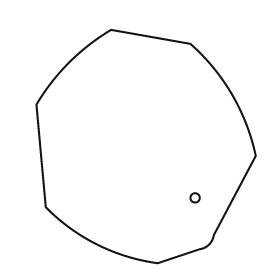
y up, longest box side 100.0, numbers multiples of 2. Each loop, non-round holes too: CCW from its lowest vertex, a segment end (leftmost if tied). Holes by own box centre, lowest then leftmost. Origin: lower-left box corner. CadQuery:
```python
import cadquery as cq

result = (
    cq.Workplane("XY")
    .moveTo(52.0, 0.0)
    .lineTo(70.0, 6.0)
    .threePointArc((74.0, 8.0), (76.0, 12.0))
    .lineTo(94.0, 46.0)
    .threePointArc((84.0, 72.0), (66.0, 94.0))
    .lineTo(32.0, 100.0)
    .threePointArc((14.0, 86.0), (0.0, 68.0))
    .lineTo(4.0, 24.0)
    .threePointArc((26.0, 8.0), (52.0, 0.0))
    .close()
    .moveTo(68.0, 28.0)
    .circle(2.0)
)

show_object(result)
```